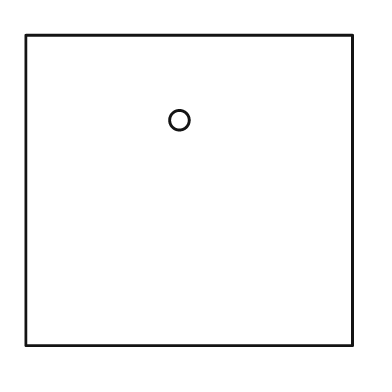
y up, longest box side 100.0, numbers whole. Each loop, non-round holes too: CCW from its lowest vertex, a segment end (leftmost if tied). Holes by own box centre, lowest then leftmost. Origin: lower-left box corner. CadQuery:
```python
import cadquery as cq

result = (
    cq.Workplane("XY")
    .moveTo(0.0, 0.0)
    .lineTo(100.0, 0.0)
    .lineTo(100.0, 95.0)
    .lineTo(0.0, 95.0)
    .close()
    .moveTo(47.0, 69.0)
    .circle(3.0)
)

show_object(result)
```